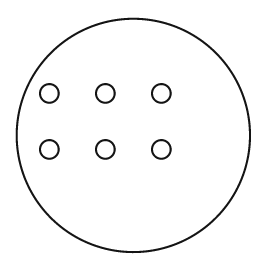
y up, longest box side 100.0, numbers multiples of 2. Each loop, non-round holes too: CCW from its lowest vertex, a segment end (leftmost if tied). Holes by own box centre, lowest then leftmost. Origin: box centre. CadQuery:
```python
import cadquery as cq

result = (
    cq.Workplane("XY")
    .moveTo(0.0, 0.0)
    .circle(50.0)
    .moveTo(-36.0, -6.0)
    .circle(4.0)
    .moveTo(-12.0, -6.0)
    .circle(4.0)
    .moveTo(12.0, -6.0)
    .circle(4.0)
    .moveTo(-36.0, 18.0)
    .circle(4.0)
    .moveTo(-12.0, 18.0)
    .circle(4.0)
    .moveTo(12.0, 18.0)
    .circle(4.0)
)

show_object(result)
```